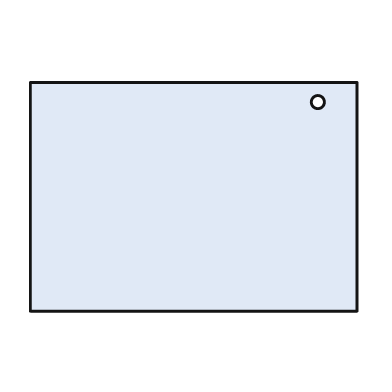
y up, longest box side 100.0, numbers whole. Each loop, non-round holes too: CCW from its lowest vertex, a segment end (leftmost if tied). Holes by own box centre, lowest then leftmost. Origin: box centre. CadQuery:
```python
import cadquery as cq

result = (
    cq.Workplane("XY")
    .moveTo(-50.0, -35.0)
    .lineTo(50.0, -35.0)
    .lineTo(50.0, 35.0)
    .lineTo(-50.0, 35.0)
    .close()
    .moveTo(38.0, 29.0)
    .circle(2.0)
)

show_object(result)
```